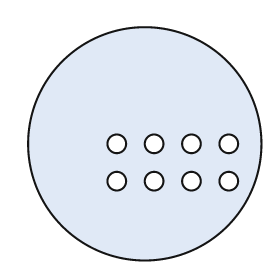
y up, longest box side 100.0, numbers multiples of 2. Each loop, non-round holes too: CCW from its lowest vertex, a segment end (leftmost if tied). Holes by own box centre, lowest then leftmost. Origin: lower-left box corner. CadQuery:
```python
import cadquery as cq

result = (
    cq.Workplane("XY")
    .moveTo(50.0, 50.0)
    .circle(50.0)
    .moveTo(38.0, 34.0)
    .circle(4.0)
    .moveTo(54.0, 34.0)
    .circle(4.0)
    .moveTo(70.0, 34.0)
    .circle(4.0)
    .moveTo(86.0, 34.0)
    .circle(4.0)
    .moveTo(38.0, 50.0)
    .circle(4.0)
    .moveTo(54.0, 50.0)
    .circle(4.0)
    .moveTo(70.0, 50.0)
    .circle(4.0)
    .moveTo(86.0, 50.0)
    .circle(4.0)
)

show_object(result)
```